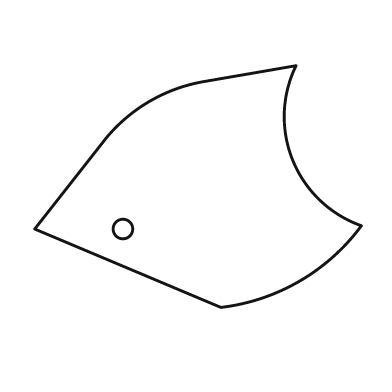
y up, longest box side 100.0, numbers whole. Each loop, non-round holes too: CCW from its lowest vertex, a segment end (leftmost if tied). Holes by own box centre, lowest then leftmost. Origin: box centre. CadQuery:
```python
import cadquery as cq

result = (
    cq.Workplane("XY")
    .moveTo(7.0, -37.0)
    .threePointArc((31.0, -29.0), (50.0, -12.0))
    .threePointArc((29.0, 8.0), (30.0, 37.0))
    .lineTo(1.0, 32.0)
    .threePointArc((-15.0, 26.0), (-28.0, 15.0))
    .lineTo(-50.0, -13.0)
    .close()
    .moveTo(-23.0, -13.0)
    .circle(3.0)
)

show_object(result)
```